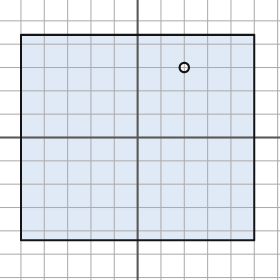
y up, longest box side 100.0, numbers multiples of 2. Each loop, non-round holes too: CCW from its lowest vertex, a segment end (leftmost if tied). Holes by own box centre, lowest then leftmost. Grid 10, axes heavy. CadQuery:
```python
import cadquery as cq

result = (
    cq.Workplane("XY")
    .moveTo(-50.0, -44.0)
    .lineTo(50.0, -44.0)
    .lineTo(50.0, 44.0)
    .lineTo(-50.0, 44.0)
    .close()
    .moveTo(20.0, 30.0)
    .circle(2.0)
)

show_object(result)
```